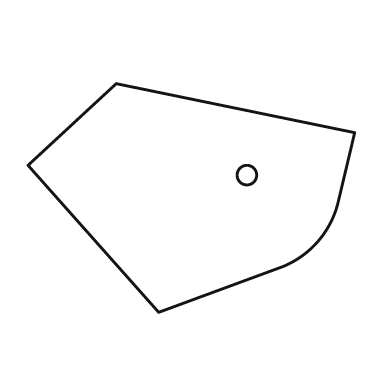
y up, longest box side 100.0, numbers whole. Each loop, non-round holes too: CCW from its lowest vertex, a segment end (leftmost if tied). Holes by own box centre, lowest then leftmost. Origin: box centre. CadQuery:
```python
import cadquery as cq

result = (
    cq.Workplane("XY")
    .moveTo(-10.0, -35.0)
    .lineTo(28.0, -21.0)
    .threePointArc((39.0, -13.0), (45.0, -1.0))
    .lineTo(50.0, 20.0)
    .lineTo(-23.0, 35.0)
    .lineTo(-50.0, 10.0)
    .close()
    .moveTo(17.0, 7.0)
    .circle(3.0)
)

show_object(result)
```